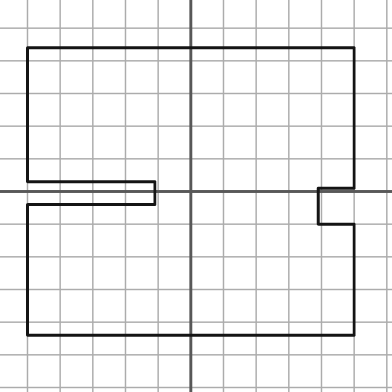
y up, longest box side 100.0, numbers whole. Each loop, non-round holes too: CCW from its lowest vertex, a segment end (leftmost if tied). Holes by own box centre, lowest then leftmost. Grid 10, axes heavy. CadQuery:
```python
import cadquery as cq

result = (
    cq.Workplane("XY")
    .moveTo(-50.0, -44.0)
    .lineTo(50.0, -44.0)
    .lineTo(50.0, -10.0)
    .lineTo(39.0, -10.0)
    .lineTo(39.0, 1.0)
    .lineTo(50.0, 1.0)
    .lineTo(50.0, 44.0)
    .lineTo(-50.0, 44.0)
    .lineTo(-50.0, 3.0)
    .lineTo(-11.0, 3.0)
    .lineTo(-11.0, -4.0)
    .lineTo(-50.0, -4.0)
    .close()
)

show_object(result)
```